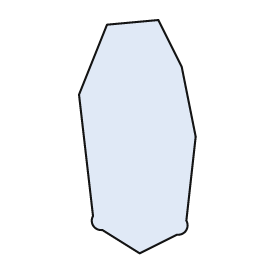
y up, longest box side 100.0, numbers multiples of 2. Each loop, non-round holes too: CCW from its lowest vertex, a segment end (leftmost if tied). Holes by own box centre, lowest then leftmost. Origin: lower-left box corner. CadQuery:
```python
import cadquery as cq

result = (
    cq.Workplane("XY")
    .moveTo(26.0, 0.0)
    .lineTo(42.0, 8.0)
    .threePointArc((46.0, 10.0), (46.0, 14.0))
    .lineTo(50.0, 50.0)
    .lineTo(44.0, 80.0)
    .lineTo(34.0, 100.0)
    .lineTo(12.0, 98.0)
    .lineTo(0.0, 68.0)
    .lineTo(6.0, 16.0)
    .threePointArc((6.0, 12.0), (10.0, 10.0))
    .close()
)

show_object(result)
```